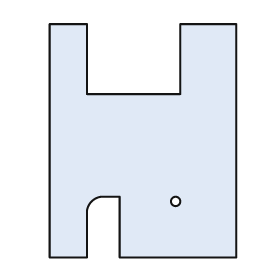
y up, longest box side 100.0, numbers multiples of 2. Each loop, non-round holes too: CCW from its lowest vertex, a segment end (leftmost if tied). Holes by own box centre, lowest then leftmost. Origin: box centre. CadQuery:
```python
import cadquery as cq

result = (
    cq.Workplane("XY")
    .moveTo(-40.0, -50.0)
    .lineTo(-24.0, -50.0)
    .lineTo(-24.0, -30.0)
    .threePointArc((-22.0, -26.0), (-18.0, -24.0))
    .lineTo(-10.0, -24.0)
    .lineTo(-10.0, -50.0)
    .lineTo(40.0, -50.0)
    .lineTo(40.0, 50.0)
    .lineTo(16.0, 50.0)
    .lineTo(16.0, 20.0)
    .lineTo(-24.0, 20.0)
    .lineTo(-24.0, 50.0)
    .lineTo(-40.0, 50.0)
    .close()
    .moveTo(14.0, -26.0)
    .circle(2.0)
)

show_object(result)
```